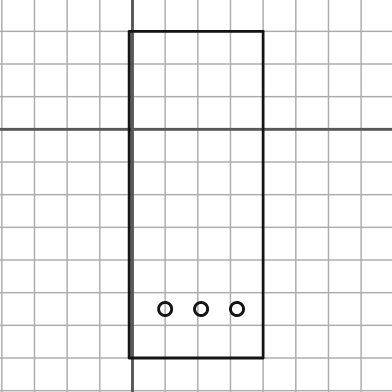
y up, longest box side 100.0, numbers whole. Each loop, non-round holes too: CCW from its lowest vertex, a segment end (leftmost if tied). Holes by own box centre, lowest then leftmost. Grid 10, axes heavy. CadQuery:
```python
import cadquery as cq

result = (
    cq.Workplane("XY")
    .moveTo(-1.0, -70.0)
    .lineTo(40.0, -70.0)
    .lineTo(40.0, 30.0)
    .lineTo(-1.0, 30.0)
    .close()
    .moveTo(10.0, -55.0)
    .circle(2.0)
    .moveTo(21.0, -55.0)
    .circle(2.0)
    .moveTo(32.0, -55.0)
    .circle(2.0)
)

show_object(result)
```